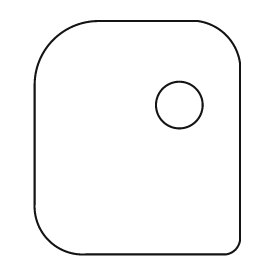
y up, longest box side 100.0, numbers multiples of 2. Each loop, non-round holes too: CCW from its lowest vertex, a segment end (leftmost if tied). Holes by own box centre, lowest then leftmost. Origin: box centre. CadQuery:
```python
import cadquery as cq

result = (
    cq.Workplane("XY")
    .moveTo(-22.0, -50.0)
    .lineTo(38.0, -50.0)
    .threePointArc((42.0, -48.0), (44.0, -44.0))
    .lineTo(44.0, 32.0)
    .threePointArc((38.0, 44.0), (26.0, 50.0))
    .lineTo(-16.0, 50.0)
    .threePointArc((-36.0, 42.0), (-44.0, 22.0))
    .lineTo(-44.0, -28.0)
    .threePointArc((-38.0, -44.0), (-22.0, -50.0))
    .close()
    .moveTo(18.0, 14.0)
    .circle(10.0)
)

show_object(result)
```